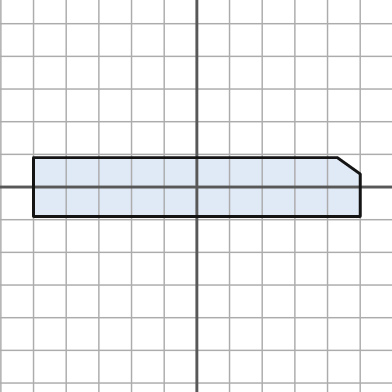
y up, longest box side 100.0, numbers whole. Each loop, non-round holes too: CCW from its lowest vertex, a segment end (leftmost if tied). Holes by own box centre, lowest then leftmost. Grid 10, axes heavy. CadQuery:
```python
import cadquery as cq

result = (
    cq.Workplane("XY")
    .moveTo(-50.0, -9.0)
    .lineTo(50.0, -9.0)
    .lineTo(50.0, 4.0)
    .lineTo(43.0, 9.0)
    .lineTo(-50.0, 9.0)
    .close()
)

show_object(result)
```